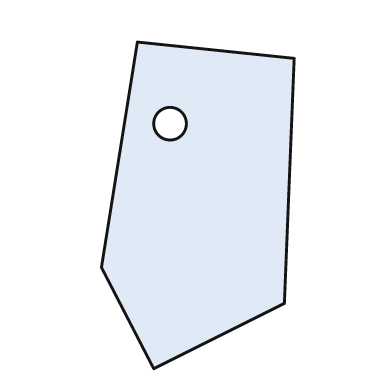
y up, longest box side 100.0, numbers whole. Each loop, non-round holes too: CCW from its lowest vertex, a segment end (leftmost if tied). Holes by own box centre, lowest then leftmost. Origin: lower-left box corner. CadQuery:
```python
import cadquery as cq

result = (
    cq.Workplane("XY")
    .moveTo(16.0, 0.0)
    .lineTo(56.0, 20.0)
    .lineTo(59.0, 95.0)
    .lineTo(11.0, 100.0)
    .lineTo(0.0, 31.0)
    .close()
    .moveTo(21.0, 75.0)
    .circle(5.0)
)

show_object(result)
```